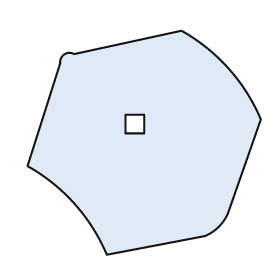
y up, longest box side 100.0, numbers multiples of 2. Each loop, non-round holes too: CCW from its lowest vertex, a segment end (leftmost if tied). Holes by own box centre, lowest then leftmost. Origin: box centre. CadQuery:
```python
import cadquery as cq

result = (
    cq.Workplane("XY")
    .moveTo(-16.0, -48.0)
    .lineTo(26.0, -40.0)
    .threePointArc((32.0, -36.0), (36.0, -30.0))
    .lineTo(50.0, 10.0)
    .threePointArc((36.0, 32.0), (16.0, 48.0))
    .lineTo(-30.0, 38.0)
    .threePointArc((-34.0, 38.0), (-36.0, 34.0))
    .lineTo(-50.0, -10.0)
    .threePointArc((-30.0, -26.0), (-16.0, -48.0))
    .close()
    .moveTo(-8.0, 4.0)
    .lineTo(0.0, 4.0)
    .lineTo(0.0, 12.0)
    .lineTo(-8.0, 12.0)
    .close()
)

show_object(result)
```